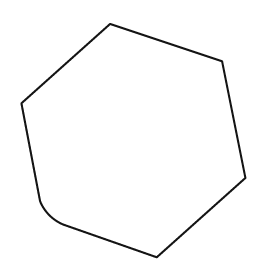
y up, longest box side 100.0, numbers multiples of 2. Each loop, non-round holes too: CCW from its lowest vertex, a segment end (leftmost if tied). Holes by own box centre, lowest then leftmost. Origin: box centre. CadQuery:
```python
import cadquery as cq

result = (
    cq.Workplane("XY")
    .moveTo(10.0, -50.0)
    .lineTo(48.0, -16.0)
    .lineTo(38.0, 34.0)
    .lineTo(-10.0, 50.0)
    .lineTo(-48.0, 16.0)
    .lineTo(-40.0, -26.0)
    .threePointArc((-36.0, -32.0), (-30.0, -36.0))
    .close()
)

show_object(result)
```